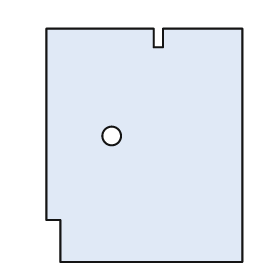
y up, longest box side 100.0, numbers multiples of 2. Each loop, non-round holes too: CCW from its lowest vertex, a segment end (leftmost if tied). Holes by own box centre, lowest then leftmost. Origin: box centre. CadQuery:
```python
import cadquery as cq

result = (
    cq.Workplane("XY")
    .moveTo(-36.0, -50.0)
    .lineTo(42.0, -50.0)
    .lineTo(42.0, 50.0)
    .lineTo(8.0, 50.0)
    .lineTo(8.0, 42.0)
    .lineTo(4.0, 42.0)
    .lineTo(4.0, 50.0)
    .lineTo(-42.0, 50.0)
    .lineTo(-42.0, -32.0)
    .lineTo(-36.0, -32.0)
    .close()
    .moveTo(-14.0, 4.0)
    .circle(4.0)
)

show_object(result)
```